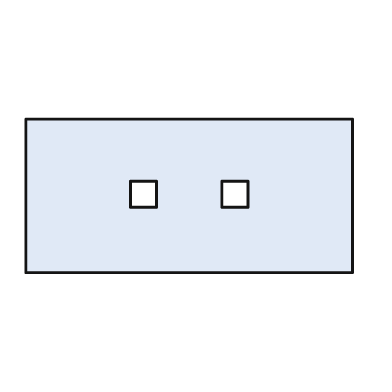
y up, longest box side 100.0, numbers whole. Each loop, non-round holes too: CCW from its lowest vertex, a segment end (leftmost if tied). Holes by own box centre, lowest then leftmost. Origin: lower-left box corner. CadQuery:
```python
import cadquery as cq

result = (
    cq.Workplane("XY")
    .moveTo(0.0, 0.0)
    .lineTo(100.0, 0.0)
    .lineTo(100.0, 47.0)
    .lineTo(0.0, 47.0)
    .close()
    .moveTo(32.0, 20.0)
    .lineTo(40.0, 20.0)
    .lineTo(40.0, 28.0)
    .lineTo(32.0, 28.0)
    .close()
    .moveTo(60.0, 20.0)
    .lineTo(68.0, 20.0)
    .lineTo(68.0, 28.0)
    .lineTo(60.0, 28.0)
    .close()
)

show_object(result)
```